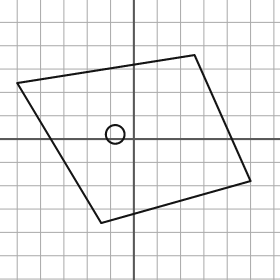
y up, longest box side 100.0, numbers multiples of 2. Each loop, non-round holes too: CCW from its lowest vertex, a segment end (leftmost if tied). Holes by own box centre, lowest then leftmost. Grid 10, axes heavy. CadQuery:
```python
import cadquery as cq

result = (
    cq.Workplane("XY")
    .moveTo(-14.0, -36.0)
    .lineTo(50.0, -18.0)
    .lineTo(26.0, 36.0)
    .lineTo(-50.0, 24.0)
    .close()
    .moveTo(-8.0, 2.0)
    .circle(4.0)
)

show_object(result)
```